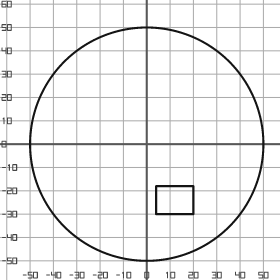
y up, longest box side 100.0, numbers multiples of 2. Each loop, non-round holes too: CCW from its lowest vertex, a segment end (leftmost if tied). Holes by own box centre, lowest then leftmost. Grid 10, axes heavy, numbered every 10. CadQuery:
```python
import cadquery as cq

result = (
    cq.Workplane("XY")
    .moveTo(0.0, 0.0)
    .circle(50.0)
    .moveTo(4.0, -30.0)
    .lineTo(20.0, -30.0)
    .lineTo(20.0, -18.0)
    .lineTo(4.0, -18.0)
    .close()
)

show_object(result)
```